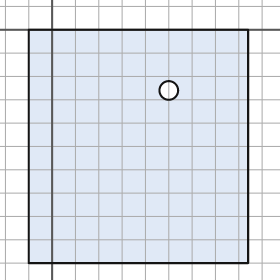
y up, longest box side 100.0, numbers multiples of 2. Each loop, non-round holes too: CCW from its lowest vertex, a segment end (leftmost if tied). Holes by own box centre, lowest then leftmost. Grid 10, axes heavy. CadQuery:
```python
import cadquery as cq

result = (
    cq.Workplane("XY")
    .moveTo(-10.0, -100.0)
    .lineTo(84.0, -100.0)
    .lineTo(84.0, 0.0)
    .lineTo(-10.0, 0.0)
    .close()
    .moveTo(50.0, -26.0)
    .circle(4.0)
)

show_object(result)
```